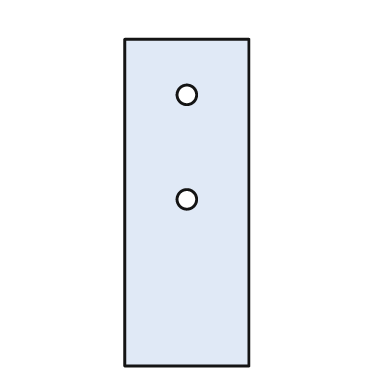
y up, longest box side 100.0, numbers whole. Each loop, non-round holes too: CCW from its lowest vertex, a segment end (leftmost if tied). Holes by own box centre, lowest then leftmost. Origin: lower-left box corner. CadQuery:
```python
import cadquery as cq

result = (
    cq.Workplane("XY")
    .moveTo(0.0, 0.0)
    .lineTo(38.0, 0.0)
    .lineTo(38.0, 100.0)
    .lineTo(0.0, 100.0)
    .close()
    .moveTo(19.0, 51.0)
    .circle(3.0)
    .moveTo(19.0, 83.0)
    .circle(3.0)
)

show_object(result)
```